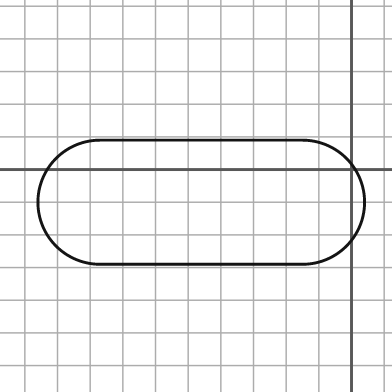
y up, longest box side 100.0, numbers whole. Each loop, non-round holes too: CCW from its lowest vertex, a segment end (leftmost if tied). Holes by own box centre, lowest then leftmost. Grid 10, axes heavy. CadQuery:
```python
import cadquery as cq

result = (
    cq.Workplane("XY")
    .moveTo(-77.0, -29.0)
    .lineTo(-15.0, -29.0)
    .threePointArc((4.0, -10.0), (-15.0, 9.0))
    .lineTo(-77.0, 9.0)
    .threePointArc((-96.0, -10.0), (-77.0, -29.0))
    .close()
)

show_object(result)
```